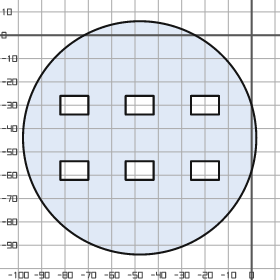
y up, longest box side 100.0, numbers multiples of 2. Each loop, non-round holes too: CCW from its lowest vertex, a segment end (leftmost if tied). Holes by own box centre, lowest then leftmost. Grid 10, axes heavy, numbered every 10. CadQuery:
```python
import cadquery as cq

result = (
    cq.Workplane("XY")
    .moveTo(-48.0, -44.0)
    .circle(50.0)
    .moveTo(-82.0, -62.0)
    .lineTo(-70.0, -62.0)
    .lineTo(-70.0, -54.0)
    .lineTo(-82.0, -54.0)
    .close()
    .moveTo(-54.0, -62.0)
    .lineTo(-42.0, -62.0)
    .lineTo(-42.0, -54.0)
    .lineTo(-54.0, -54.0)
    .close()
    .moveTo(-26.0, -62.0)
    .lineTo(-14.0, -62.0)
    .lineTo(-14.0, -54.0)
    .lineTo(-26.0, -54.0)
    .close()
    .moveTo(-82.0, -34.0)
    .lineTo(-70.0, -34.0)
    .lineTo(-70.0, -26.0)
    .lineTo(-82.0, -26.0)
    .close()
    .moveTo(-54.0, -34.0)
    .lineTo(-42.0, -34.0)
    .lineTo(-42.0, -26.0)
    .lineTo(-54.0, -26.0)
    .close()
    .moveTo(-26.0, -34.0)
    .lineTo(-14.0, -34.0)
    .lineTo(-14.0, -26.0)
    .lineTo(-26.0, -26.0)
    .close()
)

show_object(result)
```